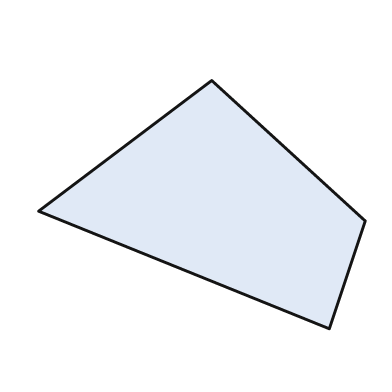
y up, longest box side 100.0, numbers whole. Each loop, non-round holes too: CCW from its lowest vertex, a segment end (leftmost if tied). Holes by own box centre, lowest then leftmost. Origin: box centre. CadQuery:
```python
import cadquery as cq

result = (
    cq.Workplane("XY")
    .moveTo(39.0, -38.0)
    .lineTo(50.0, -5.0)
    .lineTo(3.0, 38.0)
    .lineTo(-50.0, -2.0)
    .close()
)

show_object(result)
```